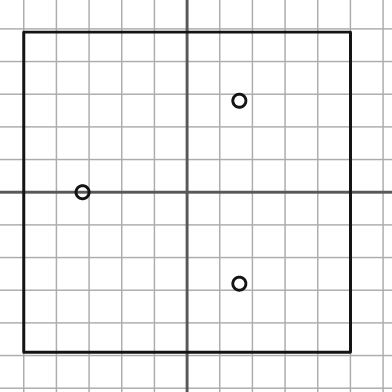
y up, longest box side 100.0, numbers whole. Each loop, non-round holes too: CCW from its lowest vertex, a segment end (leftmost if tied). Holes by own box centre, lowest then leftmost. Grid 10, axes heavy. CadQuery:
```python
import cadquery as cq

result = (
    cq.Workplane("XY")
    .moveTo(-50.0, -49.0)
    .lineTo(50.0, -49.0)
    .lineTo(50.0, 49.0)
    .lineTo(-50.0, 49.0)
    .close()
    .moveTo(16.0, -28.0)
    .circle(2.0)
    .moveTo(-32.0, 0.0)
    .circle(2.0)
    .moveTo(16.0, 28.0)
    .circle(2.0)
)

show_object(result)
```